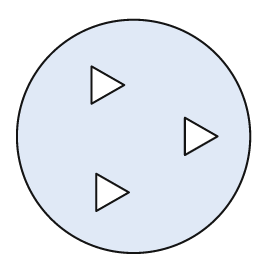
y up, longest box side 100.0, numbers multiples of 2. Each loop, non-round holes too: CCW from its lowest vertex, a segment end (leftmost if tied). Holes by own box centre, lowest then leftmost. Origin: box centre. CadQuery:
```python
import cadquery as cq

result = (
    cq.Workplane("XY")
    .moveTo(0.0, 0.0)
    .circle(50.0)
    .moveTo(-16.0, -32.0)
    .lineTo(-2.0, -24.0)
    .lineTo(-16.0, -16.0)
    .close()
    .moveTo(22.0, -8.0)
    .lineTo(36.0, 0.0)
    .lineTo(22.0, 8.0)
    .close()
    .moveTo(-18.0, 14.0)
    .lineTo(-4.0, 22.0)
    .lineTo(-18.0, 30.0)
    .close()
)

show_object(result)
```